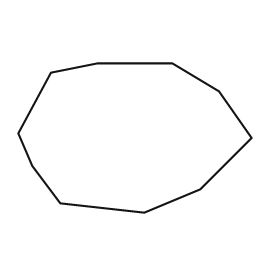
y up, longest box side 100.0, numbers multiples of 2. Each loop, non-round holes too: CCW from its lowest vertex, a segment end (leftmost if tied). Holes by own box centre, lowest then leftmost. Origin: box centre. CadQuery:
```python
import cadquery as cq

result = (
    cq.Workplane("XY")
    .moveTo(4.0, -32.0)
    .lineTo(28.0, -22.0)
    .lineTo(50.0, 0.0)
    .lineTo(36.0, 20.0)
    .lineTo(16.0, 32.0)
    .lineTo(-16.0, 32.0)
    .lineTo(-36.0, 28.0)
    .lineTo(-50.0, 2.0)
    .lineTo(-44.0, -12.0)
    .lineTo(-32.0, -28.0)
    .close()
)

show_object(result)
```